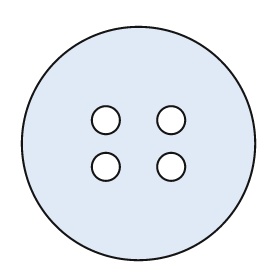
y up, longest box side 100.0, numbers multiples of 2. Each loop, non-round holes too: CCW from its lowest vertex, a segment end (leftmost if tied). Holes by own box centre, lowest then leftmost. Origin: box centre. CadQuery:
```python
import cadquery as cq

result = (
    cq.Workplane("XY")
    .moveTo(0.0, 0.0)
    .circle(50.0)
    .moveTo(-14.0, -10.0)
    .circle(6.0)
    .moveTo(14.0, -10.0)
    .circle(6.0)
    .moveTo(-14.0, 10.0)
    .circle(6.0)
    .moveTo(14.0, 10.0)
    .circle(6.0)
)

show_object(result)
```